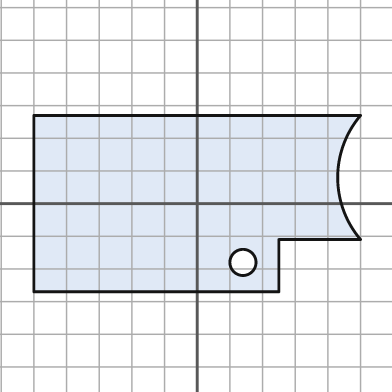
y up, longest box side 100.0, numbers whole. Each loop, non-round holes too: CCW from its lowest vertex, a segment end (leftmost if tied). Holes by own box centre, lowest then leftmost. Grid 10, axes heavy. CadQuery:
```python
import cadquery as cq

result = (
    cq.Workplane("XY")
    .moveTo(-50.0, -27.0)
    .lineTo(25.0, -27.0)
    .lineTo(25.0, -11.0)
    .lineTo(50.0, -11.0)
    .threePointArc((43.0, 8.0), (50.0, 27.0))
    .lineTo(-50.0, 27.0)
    .close()
    .moveTo(14.0, -18.0)
    .circle(4.0)
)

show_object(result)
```